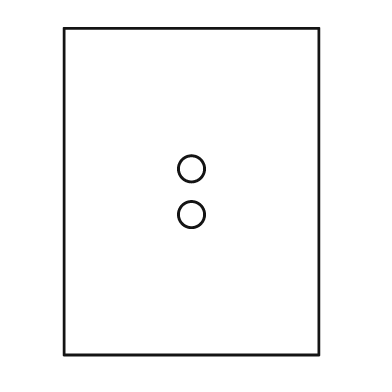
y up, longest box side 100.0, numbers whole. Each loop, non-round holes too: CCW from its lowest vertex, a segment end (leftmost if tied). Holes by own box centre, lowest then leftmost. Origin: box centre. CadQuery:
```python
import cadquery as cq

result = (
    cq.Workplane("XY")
    .moveTo(-39.0, -50.0)
    .lineTo(39.0, -50.0)
    .lineTo(39.0, 50.0)
    .lineTo(-39.0, 50.0)
    .close()
    .moveTo(0.0, -7.0)
    .circle(4.0)
    .moveTo(0.0, 7.0)
    .circle(4.0)
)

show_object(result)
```